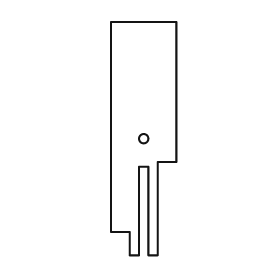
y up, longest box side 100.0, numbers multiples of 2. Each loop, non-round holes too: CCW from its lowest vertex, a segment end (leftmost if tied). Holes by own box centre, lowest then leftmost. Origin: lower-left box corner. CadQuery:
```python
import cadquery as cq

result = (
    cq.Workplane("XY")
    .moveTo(8.0, 0.0)
    .lineTo(12.0, 0.0)
    .lineTo(12.0, 38.0)
    .lineTo(16.0, 38.0)
    .lineTo(16.0, 0.0)
    .lineTo(20.0, 0.0)
    .lineTo(20.0, 40.0)
    .lineTo(28.0, 40.0)
    .lineTo(28.0, 100.0)
    .lineTo(0.0, 100.0)
    .lineTo(0.0, 10.0)
    .lineTo(8.0, 10.0)
    .close()
    .moveTo(14.0, 50.0)
    .circle(2.0)
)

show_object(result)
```